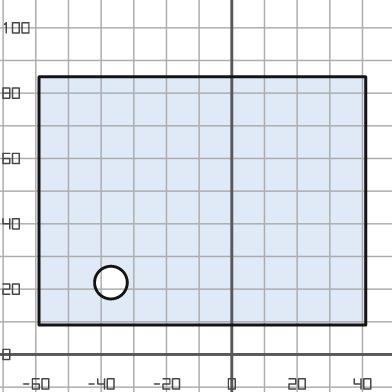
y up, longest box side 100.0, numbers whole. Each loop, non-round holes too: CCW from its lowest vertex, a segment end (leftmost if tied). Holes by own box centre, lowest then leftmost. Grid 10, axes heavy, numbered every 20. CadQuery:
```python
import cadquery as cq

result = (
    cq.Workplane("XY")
    .moveTo(-59.0, 9.0)
    .lineTo(41.0, 9.0)
    .lineTo(41.0, 85.0)
    .lineTo(-59.0, 85.0)
    .close()
    .moveTo(-37.0, 22.0)
    .circle(5.0)
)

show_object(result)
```